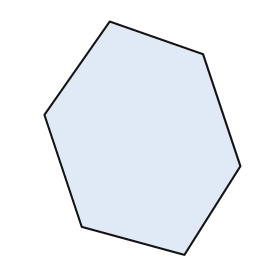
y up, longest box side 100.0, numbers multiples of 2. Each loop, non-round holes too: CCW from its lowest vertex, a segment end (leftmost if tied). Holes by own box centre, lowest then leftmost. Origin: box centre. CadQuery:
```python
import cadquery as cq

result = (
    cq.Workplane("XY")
    .moveTo(18.0, -50.0)
    .lineTo(42.0, -12.0)
    .lineTo(26.0, 36.0)
    .lineTo(-14.0, 50.0)
    .lineTo(-42.0, 10.0)
    .lineTo(-26.0, -38.0)
    .close()
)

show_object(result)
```